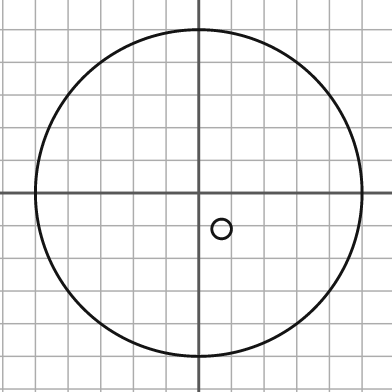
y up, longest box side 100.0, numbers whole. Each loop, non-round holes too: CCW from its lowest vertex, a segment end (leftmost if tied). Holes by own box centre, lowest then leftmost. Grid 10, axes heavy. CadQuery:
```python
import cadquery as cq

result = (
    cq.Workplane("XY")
    .moveTo(0.0, 0.0)
    .circle(50.0)
    .moveTo(7.0, -11.0)
    .circle(3.0)
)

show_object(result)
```